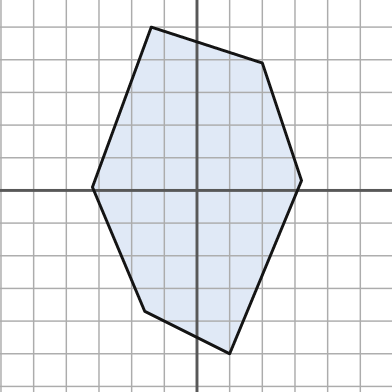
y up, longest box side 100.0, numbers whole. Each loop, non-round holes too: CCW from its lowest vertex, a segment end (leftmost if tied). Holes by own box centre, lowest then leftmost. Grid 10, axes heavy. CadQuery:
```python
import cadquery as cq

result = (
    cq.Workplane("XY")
    .moveTo(10.0, -50.0)
    .lineTo(32.0, 3.0)
    .lineTo(20.0, 39.0)
    .lineTo(-14.0, 50.0)
    .lineTo(-32.0, 1.0)
    .lineTo(-16.0, -37.0)
    .close()
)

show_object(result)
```